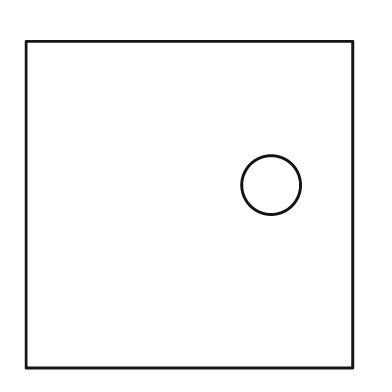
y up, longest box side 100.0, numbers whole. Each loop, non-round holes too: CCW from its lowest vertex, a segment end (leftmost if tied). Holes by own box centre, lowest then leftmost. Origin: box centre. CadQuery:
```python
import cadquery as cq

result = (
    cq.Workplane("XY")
    .moveTo(-50.0, -50.0)
    .lineTo(50.0, -50.0)
    .lineTo(50.0, 50.0)
    .lineTo(-50.0, 50.0)
    .close()
    .moveTo(25.0, 6.0)
    .circle(9.0)
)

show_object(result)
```